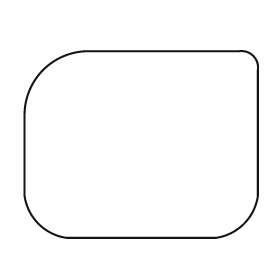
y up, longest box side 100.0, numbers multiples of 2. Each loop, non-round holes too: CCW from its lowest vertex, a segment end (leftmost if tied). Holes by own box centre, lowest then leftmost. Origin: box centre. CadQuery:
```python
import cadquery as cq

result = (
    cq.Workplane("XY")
    .moveTo(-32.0, -40.0)
    .lineTo(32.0, -40.0)
    .threePointArc((44.0, -34.0), (50.0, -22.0))
    .lineTo(50.0, 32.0)
    .threePointArc((48.0, 38.0), (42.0, 40.0))
    .lineTo(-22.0, 40.0)
    .threePointArc((-42.0, 32.0), (-50.0, 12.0))
    .lineTo(-50.0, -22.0)
    .threePointArc((-44.0, -34.0), (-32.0, -40.0))
    .close()
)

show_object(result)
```